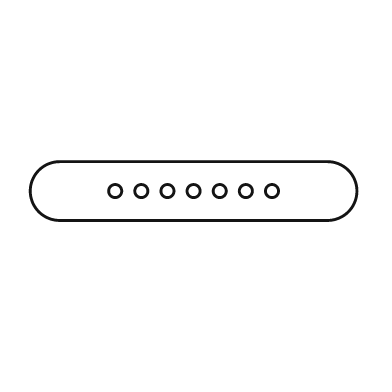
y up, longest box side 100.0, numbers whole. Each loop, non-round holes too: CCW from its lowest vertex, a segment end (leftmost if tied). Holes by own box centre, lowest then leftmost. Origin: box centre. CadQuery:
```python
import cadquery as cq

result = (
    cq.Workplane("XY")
    .moveTo(-41.0, -9.0)
    .lineTo(41.0, -9.0)
    .threePointArc((50.0, 0.0), (41.0, 9.0))
    .lineTo(-41.0, 9.0)
    .threePointArc((-50.0, 0.0), (-41.0, -9.0))
    .close()
    .moveTo(-24.0, 0.0)
    .circle(2.0)
    .moveTo(-16.0, 0.0)
    .circle(2.0)
    .moveTo(-8.0, 0.0)
    .circle(2.0)
    .moveTo(0.0, 0.0)
    .circle(2.0)
    .moveTo(8.0, 0.0)
    .circle(2.0)
    .moveTo(16.0, 0.0)
    .circle(2.0)
    .moveTo(24.0, 0.0)
    .circle(2.0)
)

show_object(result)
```